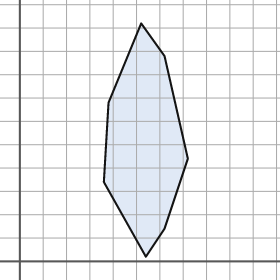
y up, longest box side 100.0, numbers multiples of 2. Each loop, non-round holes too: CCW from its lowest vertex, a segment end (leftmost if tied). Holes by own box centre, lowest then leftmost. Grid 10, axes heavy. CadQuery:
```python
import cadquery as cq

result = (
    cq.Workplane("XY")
    .moveTo(54.0, 2.0)
    .lineTo(62.0, 14.0)
    .lineTo(72.0, 44.0)
    .lineTo(62.0, 88.0)
    .lineTo(52.0, 102.0)
    .lineTo(38.0, 68.0)
    .lineTo(36.0, 34.0)
    .close()
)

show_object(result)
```